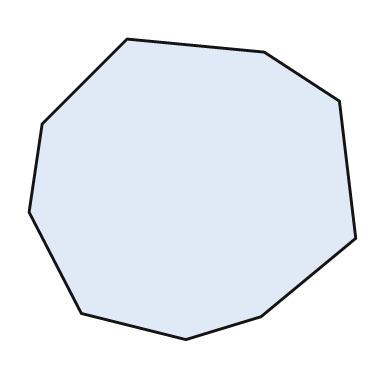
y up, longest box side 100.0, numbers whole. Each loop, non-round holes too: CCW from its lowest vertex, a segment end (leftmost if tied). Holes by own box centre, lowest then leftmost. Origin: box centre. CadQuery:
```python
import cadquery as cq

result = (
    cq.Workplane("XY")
    .moveTo(-2.0, -46.0)
    .lineTo(21.0, -39.0)
    .lineTo(50.0, -15.0)
    .lineTo(45.0, 27.0)
    .lineTo(22.0, 42.0)
    .lineTo(-20.0, 46.0)
    .lineTo(-46.0, 20.0)
    .lineTo(-50.0, -7.0)
    .lineTo(-34.0, -38.0)
    .close()
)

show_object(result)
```